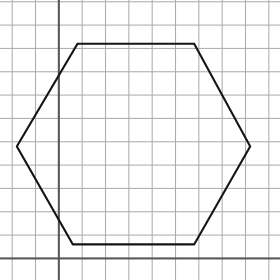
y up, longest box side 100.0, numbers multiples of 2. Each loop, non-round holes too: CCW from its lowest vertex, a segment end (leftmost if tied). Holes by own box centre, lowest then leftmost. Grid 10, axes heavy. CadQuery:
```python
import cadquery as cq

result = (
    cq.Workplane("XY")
    .moveTo(6.0, 6.0)
    .lineTo(58.0, 6.0)
    .lineTo(82.0, 48.0)
    .lineTo(58.0, 92.0)
    .lineTo(8.0, 92.0)
    .lineTo(-18.0, 48.0)
    .close()
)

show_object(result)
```